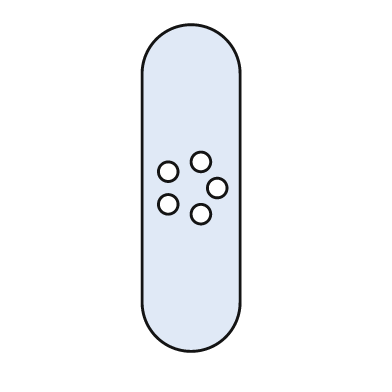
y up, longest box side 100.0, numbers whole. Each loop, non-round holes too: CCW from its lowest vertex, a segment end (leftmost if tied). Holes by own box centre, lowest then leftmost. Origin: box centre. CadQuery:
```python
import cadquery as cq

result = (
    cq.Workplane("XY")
    .moveTo(-15.0, -35.0)
    .threePointArc((0.0, -50.0), (15.0, -35.0))
    .lineTo(15.0, 35.0)
    .threePointArc((0.0, 50.0), (-15.0, 35.0))
    .close()
    .moveTo(3.0, -8.0)
    .circle(3.0)
    .moveTo(-7.0, -5.0)
    .circle(3.0)
    .moveTo(8.0, 0.0)
    .circle(3.0)
    .moveTo(-7.0, 5.0)
    .circle(3.0)
    .moveTo(3.0, 8.0)
    .circle(3.0)
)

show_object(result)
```